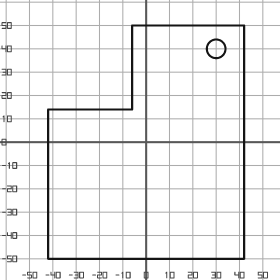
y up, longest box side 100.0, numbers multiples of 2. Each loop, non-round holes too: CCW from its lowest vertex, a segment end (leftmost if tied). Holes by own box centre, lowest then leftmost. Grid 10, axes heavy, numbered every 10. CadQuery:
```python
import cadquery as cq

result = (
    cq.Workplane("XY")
    .moveTo(-42.0, -50.0)
    .lineTo(42.0, -50.0)
    .lineTo(42.0, 50.0)
    .lineTo(-6.0, 50.0)
    .lineTo(-6.0, 14.0)
    .lineTo(-42.0, 14.0)
    .close()
    .moveTo(30.0, 40.0)
    .circle(4.0)
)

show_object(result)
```